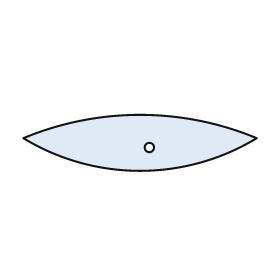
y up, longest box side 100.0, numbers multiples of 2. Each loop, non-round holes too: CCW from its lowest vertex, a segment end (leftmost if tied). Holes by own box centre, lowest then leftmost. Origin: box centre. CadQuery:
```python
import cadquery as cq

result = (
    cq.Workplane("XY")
    .moveTo(-50.0, 2.0)
    .threePointArc((0.0, -12.0), (50.0, 2.0))
    .threePointArc((0.0, 12.0), (-50.0, 2.0))
    .close()
    .moveTo(4.0, -2.0)
    .circle(2.0)
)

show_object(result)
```